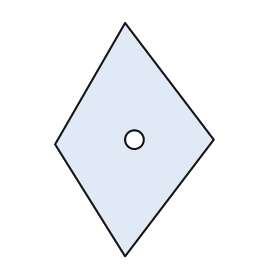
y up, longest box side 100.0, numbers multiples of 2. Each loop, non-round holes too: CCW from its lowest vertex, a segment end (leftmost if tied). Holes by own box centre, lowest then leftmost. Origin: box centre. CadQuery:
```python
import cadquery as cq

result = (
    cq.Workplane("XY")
    .moveTo(-4.0, -50.0)
    .lineTo(34.0, 0.0)
    .lineTo(-4.0, 50.0)
    .lineTo(-34.0, -2.0)
    .close()
    .moveTo(0.0, 0.0)
    .circle(4.0)
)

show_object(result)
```